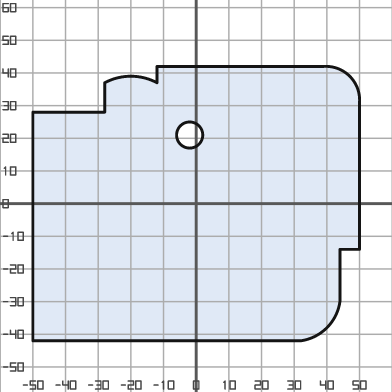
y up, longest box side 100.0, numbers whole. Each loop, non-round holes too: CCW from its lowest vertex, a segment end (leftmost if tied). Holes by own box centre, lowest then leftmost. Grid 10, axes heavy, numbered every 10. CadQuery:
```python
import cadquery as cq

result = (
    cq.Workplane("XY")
    .moveTo(-50.0, -42.0)
    .lineTo(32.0, -42.0)
    .threePointArc((40.0, -38.0), (44.0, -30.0))
    .lineTo(44.0, -14.0)
    .lineTo(50.0, -14.0)
    .lineTo(50.0, 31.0)
    .threePointArc((47.0, 39.0), (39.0, 42.0))
    .lineTo(-12.0, 42.0)
    .lineTo(-12.0, 37.0)
    .threePointArc((-20.0, 39.0), (-28.0, 37.0))
    .lineTo(-28.0, 28.0)
    .lineTo(-50.0, 28.0)
    .close()
    .moveTo(-2.0, 21.0)
    .circle(4.0)
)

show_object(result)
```